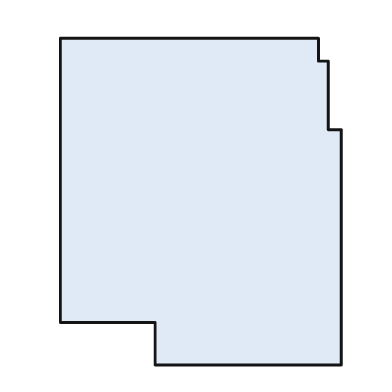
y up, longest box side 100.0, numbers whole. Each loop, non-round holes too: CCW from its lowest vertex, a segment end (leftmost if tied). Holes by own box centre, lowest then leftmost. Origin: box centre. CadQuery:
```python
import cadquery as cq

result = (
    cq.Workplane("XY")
    .moveTo(-14.0, -50.0)
    .lineTo(43.0, -50.0)
    .lineTo(43.0, 22.0)
    .lineTo(39.0, 22.0)
    .lineTo(39.0, 43.0)
    .lineTo(36.0, 43.0)
    .lineTo(36.0, 50.0)
    .lineTo(-43.0, 50.0)
    .lineTo(-43.0, -37.0)
    .lineTo(-14.0, -37.0)
    .close()
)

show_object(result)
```